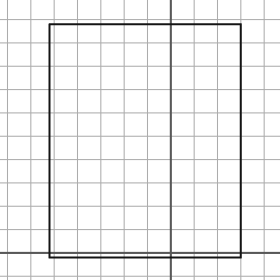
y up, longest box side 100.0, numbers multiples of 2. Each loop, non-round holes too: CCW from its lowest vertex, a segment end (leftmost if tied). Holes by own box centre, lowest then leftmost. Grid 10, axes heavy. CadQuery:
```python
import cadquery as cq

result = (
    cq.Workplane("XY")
    .moveTo(-52.0, -2.0)
    .lineTo(30.0, -2.0)
    .lineTo(30.0, 98.0)
    .lineTo(-52.0, 98.0)
    .close()
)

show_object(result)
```